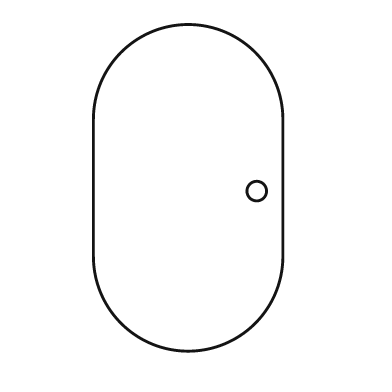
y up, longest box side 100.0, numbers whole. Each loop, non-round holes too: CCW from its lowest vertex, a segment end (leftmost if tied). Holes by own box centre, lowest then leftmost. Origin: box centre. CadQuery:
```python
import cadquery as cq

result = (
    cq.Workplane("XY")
    .moveTo(-29.0, -21.0)
    .threePointArc((0.0, -50.0), (29.0, -21.0))
    .lineTo(29.0, 21.0)
    .threePointArc((0.0, 50.0), (-29.0, 21.0))
    .close()
    .moveTo(21.0, -1.0)
    .circle(3.0)
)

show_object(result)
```